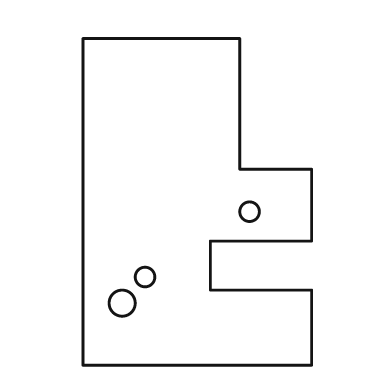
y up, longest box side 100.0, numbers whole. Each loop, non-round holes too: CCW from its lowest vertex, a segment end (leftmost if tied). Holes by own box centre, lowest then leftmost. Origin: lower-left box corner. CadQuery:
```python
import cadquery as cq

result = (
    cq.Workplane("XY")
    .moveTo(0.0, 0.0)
    .lineTo(70.0, 0.0)
    .lineTo(70.0, 23.0)
    .lineTo(39.0, 23.0)
    .lineTo(39.0, 38.0)
    .lineTo(70.0, 38.0)
    .lineTo(70.0, 60.0)
    .lineTo(48.0, 60.0)
    .lineTo(48.0, 100.0)
    .lineTo(0.0, 100.0)
    .close()
    .moveTo(12.0, 19.0)
    .circle(4.0)
    .moveTo(19.0, 27.0)
    .circle(3.0)
    .moveTo(51.0, 47.0)
    .circle(3.0)
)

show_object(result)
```